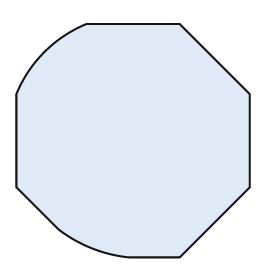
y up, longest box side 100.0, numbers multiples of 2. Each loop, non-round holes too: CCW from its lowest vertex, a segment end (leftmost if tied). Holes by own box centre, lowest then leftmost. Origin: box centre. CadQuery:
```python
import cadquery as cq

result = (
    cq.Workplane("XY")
    .moveTo(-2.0, -50.0)
    .lineTo(20.0, -50.0)
    .lineTo(50.0, -20.0)
    .lineTo(50.0, 20.0)
    .lineTo(20.0, 50.0)
    .lineTo(-20.0, 50.0)
    .threePointArc((-38.0, 38.0), (-50.0, 20.0))
    .lineTo(-50.0, -20.0)
    .lineTo(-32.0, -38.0)
    .threePointArc((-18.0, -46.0), (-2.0, -50.0))
    .close()
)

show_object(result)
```